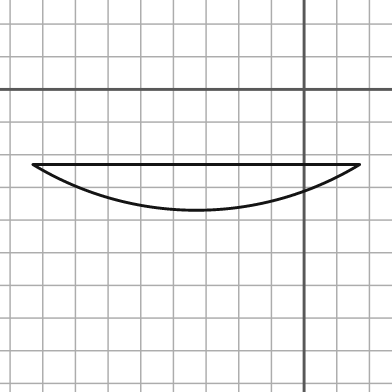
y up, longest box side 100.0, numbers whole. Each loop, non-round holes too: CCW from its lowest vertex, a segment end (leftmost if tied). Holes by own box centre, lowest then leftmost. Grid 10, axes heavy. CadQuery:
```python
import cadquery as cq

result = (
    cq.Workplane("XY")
    .moveTo(-83.0, -23.0)
    .threePointArc((-33.0, -37.0), (17.0, -23.0))
    .close()
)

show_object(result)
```